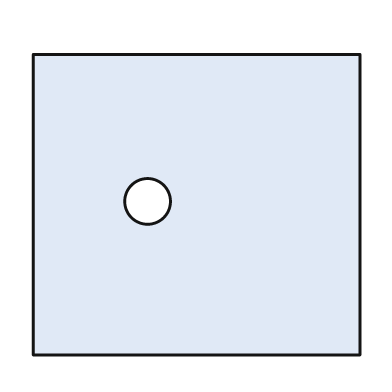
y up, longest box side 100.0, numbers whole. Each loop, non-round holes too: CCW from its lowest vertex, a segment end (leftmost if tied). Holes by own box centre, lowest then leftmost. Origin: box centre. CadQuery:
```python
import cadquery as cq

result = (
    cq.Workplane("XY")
    .moveTo(-50.0, -46.0)
    .lineTo(50.0, -46.0)
    .lineTo(50.0, 46.0)
    .lineTo(-50.0, 46.0)
    .close()
    .moveTo(-15.0, 1.0)
    .circle(7.0)
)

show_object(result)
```